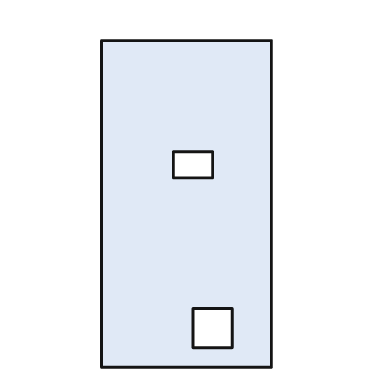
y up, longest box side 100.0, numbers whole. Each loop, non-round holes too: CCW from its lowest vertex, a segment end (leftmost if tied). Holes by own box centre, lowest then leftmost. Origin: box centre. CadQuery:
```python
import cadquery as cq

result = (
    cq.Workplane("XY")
    .moveTo(-26.0, -50.0)
    .lineTo(26.0, -50.0)
    .lineTo(26.0, 50.0)
    .lineTo(-26.0, 50.0)
    .close()
    .moveTo(2.0, -44.0)
    .lineTo(14.0, -44.0)
    .lineTo(14.0, -32.0)
    .lineTo(2.0, -32.0)
    .close()
    .moveTo(-4.0, 8.0)
    .lineTo(8.0, 8.0)
    .lineTo(8.0, 16.0)
    .lineTo(-4.0, 16.0)
    .close()
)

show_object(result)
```